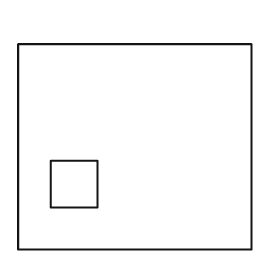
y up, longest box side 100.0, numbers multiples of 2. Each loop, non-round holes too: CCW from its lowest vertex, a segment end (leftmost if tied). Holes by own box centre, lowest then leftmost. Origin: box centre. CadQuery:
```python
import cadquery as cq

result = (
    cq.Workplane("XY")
    .moveTo(-50.0, -44.0)
    .lineTo(50.0, -44.0)
    .lineTo(50.0, 44.0)
    .lineTo(-50.0, 44.0)
    .close()
    .moveTo(-36.0, -26.0)
    .lineTo(-16.0, -26.0)
    .lineTo(-16.0, -6.0)
    .lineTo(-36.0, -6.0)
    .close()
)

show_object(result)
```